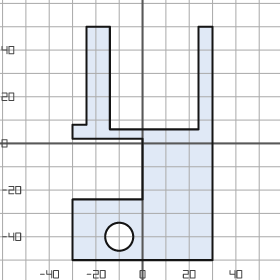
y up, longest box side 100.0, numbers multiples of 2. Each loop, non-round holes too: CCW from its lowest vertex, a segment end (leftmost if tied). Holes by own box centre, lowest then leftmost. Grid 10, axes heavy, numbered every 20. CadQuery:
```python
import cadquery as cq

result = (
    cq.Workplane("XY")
    .moveTo(-30.0, -50.0)
    .lineTo(30.0, -50.0)
    .lineTo(30.0, 50.0)
    .lineTo(24.0, 50.0)
    .lineTo(24.0, 6.0)
    .lineTo(-14.0, 6.0)
    .lineTo(-14.0, 50.0)
    .lineTo(-24.0, 50.0)
    .lineTo(-24.0, 8.0)
    .lineTo(-30.0, 8.0)
    .lineTo(-30.0, 2.0)
    .lineTo(0.0, 2.0)
    .lineTo(0.0, -24.0)
    .lineTo(-30.0, -24.0)
    .close()
    .moveTo(-10.0, -40.0)
    .circle(6.0)
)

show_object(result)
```